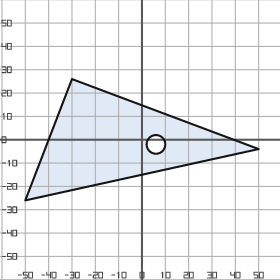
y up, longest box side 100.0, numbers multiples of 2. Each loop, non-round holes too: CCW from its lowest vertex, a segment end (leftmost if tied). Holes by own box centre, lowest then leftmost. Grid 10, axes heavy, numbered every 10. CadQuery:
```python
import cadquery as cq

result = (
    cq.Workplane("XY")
    .moveTo(-50.0, -26.0)
    .lineTo(50.0, -4.0)
    .lineTo(-30.0, 26.0)
    .close()
    .moveTo(6.0, -2.0)
    .circle(4.0)
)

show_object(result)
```